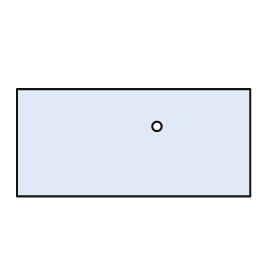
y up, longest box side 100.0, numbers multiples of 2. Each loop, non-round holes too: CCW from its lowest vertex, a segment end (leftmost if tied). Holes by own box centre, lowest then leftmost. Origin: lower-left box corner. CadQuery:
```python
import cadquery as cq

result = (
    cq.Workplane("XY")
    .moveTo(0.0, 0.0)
    .lineTo(100.0, 0.0)
    .lineTo(100.0, 46.0)
    .lineTo(0.0, 46.0)
    .close()
    .moveTo(60.0, 30.0)
    .circle(2.0)
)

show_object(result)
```